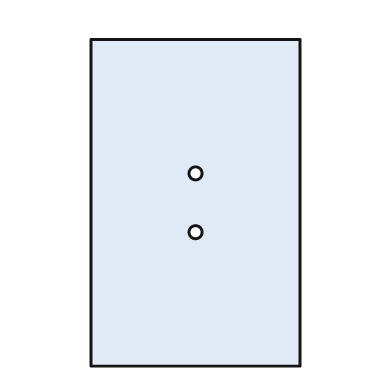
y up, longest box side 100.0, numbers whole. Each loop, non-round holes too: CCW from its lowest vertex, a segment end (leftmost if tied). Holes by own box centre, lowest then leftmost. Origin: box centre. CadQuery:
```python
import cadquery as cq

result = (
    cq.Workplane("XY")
    .moveTo(-32.0, -50.0)
    .lineTo(32.0, -50.0)
    .lineTo(32.0, 50.0)
    .lineTo(-32.0, 50.0)
    .close()
    .moveTo(0.0, -9.0)
    .circle(2.0)
    .moveTo(0.0, 9.0)
    .circle(2.0)
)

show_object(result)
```